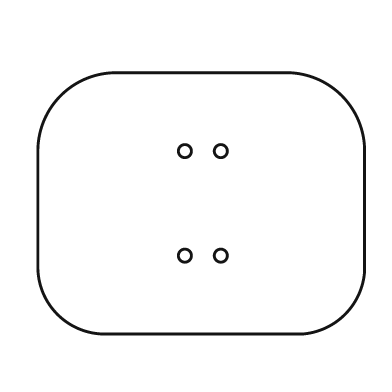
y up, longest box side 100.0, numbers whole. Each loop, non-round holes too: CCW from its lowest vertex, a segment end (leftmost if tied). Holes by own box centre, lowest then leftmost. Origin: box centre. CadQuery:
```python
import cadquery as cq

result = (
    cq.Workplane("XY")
    .moveTo(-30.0, -40.0)
    .lineTo(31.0, -40.0)
    .threePointArc((44.0, -34.0), (50.0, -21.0))
    .lineTo(50.0, 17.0)
    .threePointArc((43.0, 33.0), (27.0, 40.0))
    .lineTo(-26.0, 40.0)
    .threePointArc((-43.0, 33.0), (-50.0, 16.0))
    .lineTo(-50.0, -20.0)
    .threePointArc((-44.0, -34.0), (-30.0, -40.0))
    .close()
    .moveTo(-5.0, -16.0)
    .circle(2.0)
    .moveTo(6.0, -16.0)
    .circle(2.0)
    .moveTo(-5.0, 16.0)
    .circle(2.0)
    .moveTo(6.0, 16.0)
    .circle(2.0)
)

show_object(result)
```